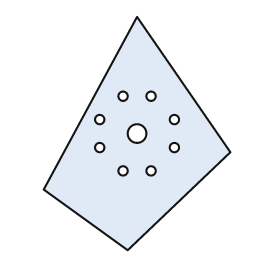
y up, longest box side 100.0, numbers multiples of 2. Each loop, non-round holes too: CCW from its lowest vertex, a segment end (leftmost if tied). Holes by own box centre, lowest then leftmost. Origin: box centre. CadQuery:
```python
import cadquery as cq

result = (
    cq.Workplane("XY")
    .moveTo(-4.0, -50.0)
    .lineTo(40.0, -8.0)
    .lineTo(0.0, 50.0)
    .lineTo(-40.0, -24.0)
    .close()
    .moveTo(-6.0, -16.0)
    .circle(2.0)
    .moveTo(6.0, -16.0)
    .circle(2.0)
    .moveTo(-16.0, -6.0)
    .circle(2.0)
    .moveTo(16.0, -6.0)
    .circle(2.0)
    .moveTo(0.0, 0.0)
    .circle(4.0)
    .moveTo(-16.0, 6.0)
    .circle(2.0)
    .moveTo(16.0, 6.0)
    .circle(2.0)
    .moveTo(-6.0, 16.0)
    .circle(2.0)
    .moveTo(6.0, 16.0)
    .circle(2.0)
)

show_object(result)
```